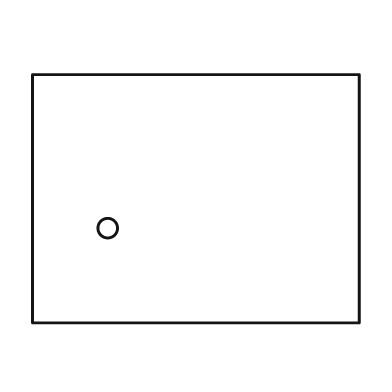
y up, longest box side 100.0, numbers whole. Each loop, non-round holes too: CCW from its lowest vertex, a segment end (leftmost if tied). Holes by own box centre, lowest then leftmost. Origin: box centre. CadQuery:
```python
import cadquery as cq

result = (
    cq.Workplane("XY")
    .moveTo(-50.0, -38.0)
    .lineTo(50.0, -38.0)
    .lineTo(50.0, 38.0)
    .lineTo(-50.0, 38.0)
    .close()
    .moveTo(-27.0, -9.0)
    .circle(3.0)
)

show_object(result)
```